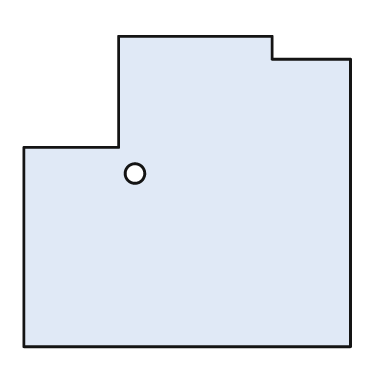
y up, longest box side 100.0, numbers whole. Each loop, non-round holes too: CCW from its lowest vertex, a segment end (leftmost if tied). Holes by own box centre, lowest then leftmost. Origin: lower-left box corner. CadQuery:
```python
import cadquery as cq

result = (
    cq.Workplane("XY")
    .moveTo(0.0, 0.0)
    .lineTo(100.0, 0.0)
    .lineTo(100.0, 88.0)
    .lineTo(76.0, 88.0)
    .lineTo(76.0, 95.0)
    .lineTo(29.0, 95.0)
    .lineTo(29.0, 61.0)
    .lineTo(0.0, 61.0)
    .close()
    .moveTo(34.0, 53.0)
    .circle(3.0)
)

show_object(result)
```